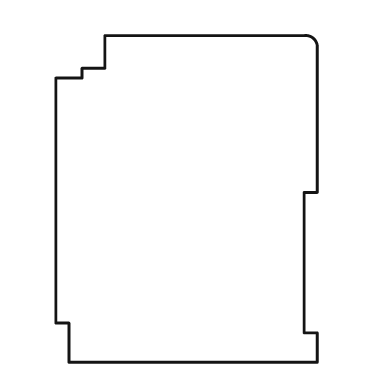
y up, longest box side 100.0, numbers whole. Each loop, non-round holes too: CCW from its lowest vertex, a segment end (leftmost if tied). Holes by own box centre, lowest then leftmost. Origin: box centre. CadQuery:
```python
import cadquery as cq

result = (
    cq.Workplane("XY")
    .moveTo(-36.0, -50.0)
    .lineTo(40.0, -50.0)
    .lineTo(40.0, -41.0)
    .lineTo(36.0, -41.0)
    .lineTo(36.0, 2.0)
    .lineTo(40.0, 2.0)
    .lineTo(40.0, 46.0)
    .threePointArc((39.0, 49.0), (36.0, 50.0))
    .lineTo(-25.0, 50.0)
    .lineTo(-25.0, 40.0)
    .lineTo(-32.0, 40.0)
    .lineTo(-32.0, 37.0)
    .lineTo(-40.0, 37.0)
    .lineTo(-40.0, -38.0)
    .lineTo(-36.0, -38.0)
    .close()
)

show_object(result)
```